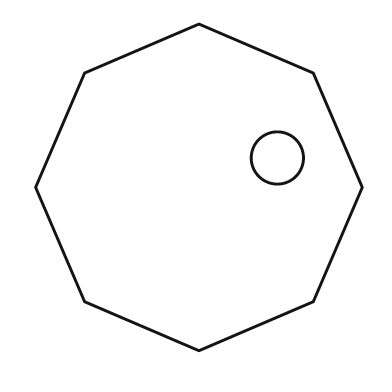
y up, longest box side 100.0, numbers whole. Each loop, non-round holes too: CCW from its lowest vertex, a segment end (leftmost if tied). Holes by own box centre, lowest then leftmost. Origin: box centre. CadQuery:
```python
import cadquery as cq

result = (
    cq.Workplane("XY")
    .moveTo(0.0, -50.0)
    .lineTo(35.0, -35.0)
    .lineTo(50.0, 0.0)
    .lineTo(35.0, 35.0)
    .lineTo(0.0, 50.0)
    .lineTo(-35.0, 35.0)
    .lineTo(-50.0, 0.0)
    .lineTo(-35.0, -35.0)
    .close()
    .moveTo(24.0, 9.0)
    .circle(8.0)
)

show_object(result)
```